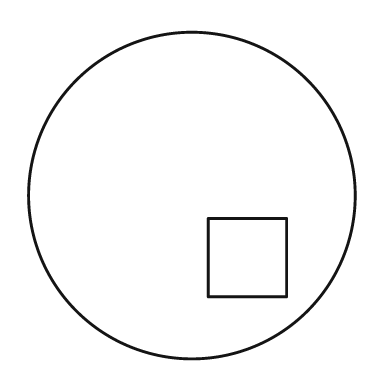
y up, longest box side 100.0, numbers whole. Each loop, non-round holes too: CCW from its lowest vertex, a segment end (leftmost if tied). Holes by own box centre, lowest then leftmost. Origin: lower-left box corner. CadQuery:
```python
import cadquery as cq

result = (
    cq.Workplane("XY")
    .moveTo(50.0, 50.0)
    .circle(50.0)
    .moveTo(55.0, 19.0)
    .lineTo(79.0, 19.0)
    .lineTo(79.0, 43.0)
    .lineTo(55.0, 43.0)
    .close()
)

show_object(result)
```